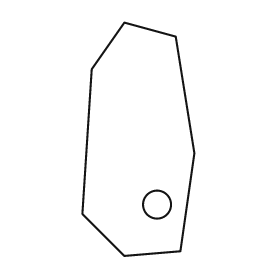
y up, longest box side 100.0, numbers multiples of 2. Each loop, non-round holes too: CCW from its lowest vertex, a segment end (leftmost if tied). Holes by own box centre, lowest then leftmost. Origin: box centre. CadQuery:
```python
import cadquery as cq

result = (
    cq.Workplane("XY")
    .moveTo(-6.0, -50.0)
    .lineTo(18.0, -48.0)
    .lineTo(24.0, -6.0)
    .lineTo(16.0, 44.0)
    .lineTo(-6.0, 50.0)
    .lineTo(-20.0, 30.0)
    .lineTo(-24.0, -32.0)
    .close()
    .moveTo(8.0, -28.0)
    .circle(6.0)
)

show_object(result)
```